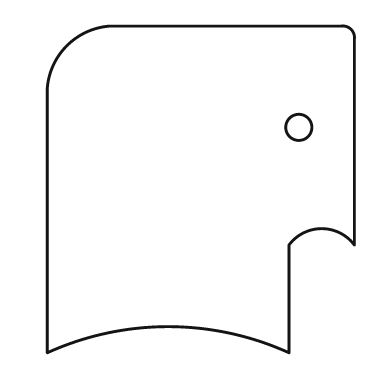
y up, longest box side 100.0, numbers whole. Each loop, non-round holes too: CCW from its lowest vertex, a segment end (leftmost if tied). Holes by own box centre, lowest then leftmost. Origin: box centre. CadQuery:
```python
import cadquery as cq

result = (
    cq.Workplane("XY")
    .moveTo(-47.0, -50.0)
    .threePointArc((-10.0, -42.0), (27.0, -50.0))
    .lineTo(27.0, -17.0)
    .threePointArc((37.0, -12.0), (47.0, -17.0))
    .lineTo(47.0, 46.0)
    .threePointArc((46.0, 49.0), (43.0, 50.0))
    .lineTo(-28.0, 50.0)
    .threePointArc((-41.0, 44.0), (-47.0, 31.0))
    .close()
    .moveTo(30.0, 19.0)
    .circle(4.0)
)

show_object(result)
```